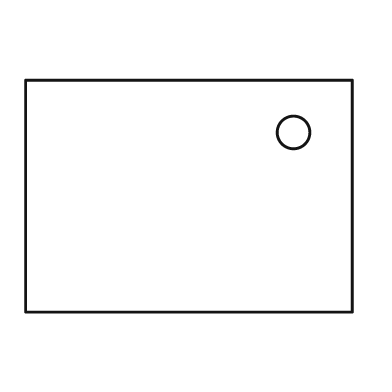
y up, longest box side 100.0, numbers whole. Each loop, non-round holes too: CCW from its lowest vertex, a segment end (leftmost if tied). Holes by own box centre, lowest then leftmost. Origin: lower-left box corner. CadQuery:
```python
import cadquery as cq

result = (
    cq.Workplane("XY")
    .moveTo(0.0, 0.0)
    .lineTo(100.0, 0.0)
    .lineTo(100.0, 71.0)
    .lineTo(0.0, 71.0)
    .close()
    .moveTo(82.0, 55.0)
    .circle(5.0)
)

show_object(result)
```